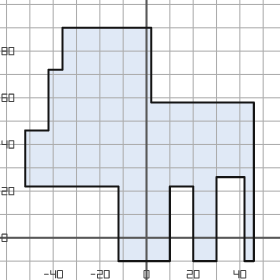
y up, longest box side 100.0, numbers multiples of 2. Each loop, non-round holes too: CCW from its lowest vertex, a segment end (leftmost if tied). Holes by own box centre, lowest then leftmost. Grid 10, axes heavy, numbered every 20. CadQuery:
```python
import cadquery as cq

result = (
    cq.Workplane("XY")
    .moveTo(-12.0, -10.0)
    .lineTo(10.0, -10.0)
    .lineTo(10.0, 22.0)
    .lineTo(20.0, 22.0)
    .lineTo(20.0, -10.0)
    .lineTo(30.0, -10.0)
    .lineTo(30.0, 26.0)
    .lineTo(42.0, 26.0)
    .lineTo(42.0, -10.0)
    .lineTo(46.0, -10.0)
    .lineTo(46.0, 58.0)
    .lineTo(2.0, 58.0)
    .lineTo(2.0, 90.0)
    .lineTo(-36.0, 90.0)
    .lineTo(-36.0, 72.0)
    .lineTo(-42.0, 72.0)
    .lineTo(-42.0, 46.0)
    .lineTo(-52.0, 46.0)
    .lineTo(-52.0, 22.0)
    .lineTo(-12.0, 22.0)
    .close()
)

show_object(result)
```